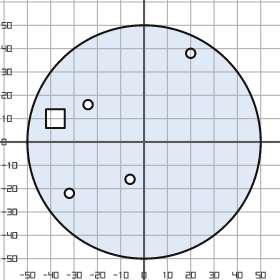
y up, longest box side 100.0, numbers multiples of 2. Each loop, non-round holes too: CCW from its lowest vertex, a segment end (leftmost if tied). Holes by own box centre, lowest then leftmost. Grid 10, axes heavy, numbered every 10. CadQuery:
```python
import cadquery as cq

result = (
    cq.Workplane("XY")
    .moveTo(0.0, 0.0)
    .circle(50.0)
    .moveTo(-32.0, -22.0)
    .circle(2.0)
    .moveTo(-6.0, -16.0)
    .circle(2.0)
    .moveTo(-42.0, 6.0)
    .lineTo(-34.0, 6.0)
    .lineTo(-34.0, 14.0)
    .lineTo(-42.0, 14.0)
    .close()
    .moveTo(-24.0, 16.0)
    .circle(2.0)
    .moveTo(20.0, 38.0)
    .circle(2.0)
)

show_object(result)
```